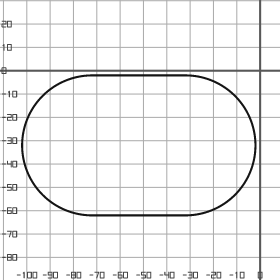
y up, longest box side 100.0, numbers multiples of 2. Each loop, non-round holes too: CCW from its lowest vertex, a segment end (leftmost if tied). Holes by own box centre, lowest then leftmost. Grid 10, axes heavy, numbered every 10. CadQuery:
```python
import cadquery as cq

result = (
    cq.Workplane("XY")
    .moveTo(-72.0, -62.0)
    .lineTo(-32.0, -62.0)
    .threePointArc((-2.0, -32.0), (-32.0, -2.0))
    .lineTo(-72.0, -2.0)
    .threePointArc((-102.0, -32.0), (-72.0, -62.0))
    .close()
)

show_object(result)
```